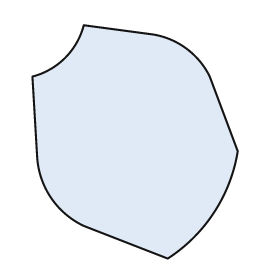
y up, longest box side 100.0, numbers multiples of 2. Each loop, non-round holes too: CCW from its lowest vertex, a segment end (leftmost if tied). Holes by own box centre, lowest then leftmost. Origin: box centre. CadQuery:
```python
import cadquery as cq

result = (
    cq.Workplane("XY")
    .moveTo(14.0, -50.0)
    .threePointArc((34.0, -30.0), (44.0, -4.0))
    .lineTo(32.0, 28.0)
    .threePointArc((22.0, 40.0), (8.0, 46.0))
    .lineTo(-22.0, 50.0)
    .threePointArc((-30.0, 36.0), (-44.0, 28.0))
    .lineTo(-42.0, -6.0)
    .threePointArc((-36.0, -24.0), (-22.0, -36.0))
    .close()
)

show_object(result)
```